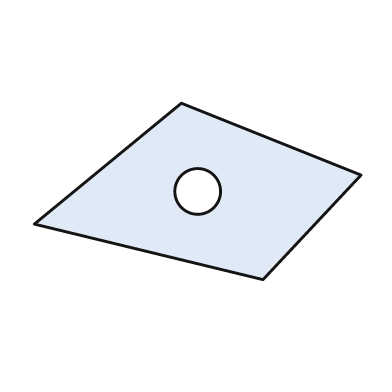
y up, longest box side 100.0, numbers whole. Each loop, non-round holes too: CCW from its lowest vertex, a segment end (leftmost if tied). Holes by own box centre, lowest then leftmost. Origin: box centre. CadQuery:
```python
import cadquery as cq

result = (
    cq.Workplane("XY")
    .moveTo(20.0, -27.0)
    .lineTo(50.0, 5.0)
    .lineTo(-5.0, 27.0)
    .lineTo(-50.0, -10.0)
    .close()
    .moveTo(0.0, 0.0)
    .circle(7.0)
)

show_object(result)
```